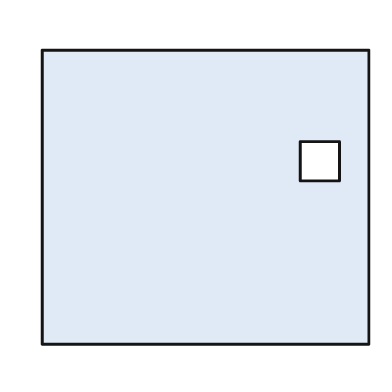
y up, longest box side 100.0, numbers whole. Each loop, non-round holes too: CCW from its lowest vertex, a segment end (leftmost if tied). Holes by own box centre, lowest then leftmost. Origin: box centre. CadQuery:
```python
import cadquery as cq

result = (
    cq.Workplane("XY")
    .moveTo(-50.0, -45.0)
    .lineTo(50.0, -45.0)
    .lineTo(50.0, 45.0)
    .lineTo(-50.0, 45.0)
    .close()
    .moveTo(29.0, 5.0)
    .lineTo(41.0, 5.0)
    .lineTo(41.0, 17.0)
    .lineTo(29.0, 17.0)
    .close()
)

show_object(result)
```